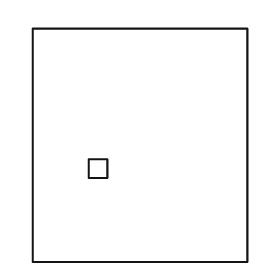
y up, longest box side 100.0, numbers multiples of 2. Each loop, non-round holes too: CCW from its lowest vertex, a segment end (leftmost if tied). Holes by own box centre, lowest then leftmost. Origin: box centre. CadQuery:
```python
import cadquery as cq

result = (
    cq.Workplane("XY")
    .moveTo(-46.0, -50.0)
    .lineTo(46.0, -50.0)
    .lineTo(46.0, 50.0)
    .lineTo(-46.0, 50.0)
    .close()
    .moveTo(-22.0, -14.0)
    .lineTo(-14.0, -14.0)
    .lineTo(-14.0, -6.0)
    .lineTo(-22.0, -6.0)
    .close()
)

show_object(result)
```